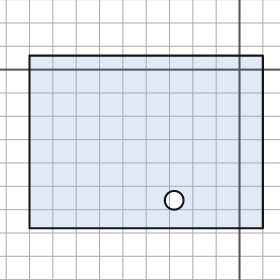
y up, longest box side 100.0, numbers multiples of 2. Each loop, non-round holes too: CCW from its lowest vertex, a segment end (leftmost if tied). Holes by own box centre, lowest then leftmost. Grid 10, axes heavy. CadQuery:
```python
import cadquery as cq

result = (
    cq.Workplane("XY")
    .moveTo(-90.0, -68.0)
    .lineTo(10.0, -68.0)
    .lineTo(10.0, 6.0)
    .lineTo(-90.0, 6.0)
    .close()
    .moveTo(-28.0, -56.0)
    .circle(4.0)
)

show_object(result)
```